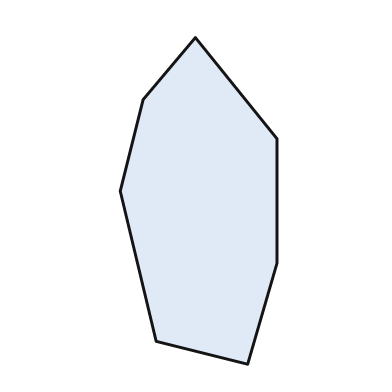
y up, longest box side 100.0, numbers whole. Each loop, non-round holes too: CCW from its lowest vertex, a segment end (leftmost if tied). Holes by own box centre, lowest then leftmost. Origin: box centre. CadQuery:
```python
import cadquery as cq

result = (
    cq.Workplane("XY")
    .moveTo(15.0, -50.0)
    .lineTo(24.0, -19.0)
    .lineTo(24.0, 19.0)
    .lineTo(-1.0, 50.0)
    .lineTo(-17.0, 31.0)
    .lineTo(-24.0, 3.0)
    .lineTo(-13.0, -43.0)
    .close()
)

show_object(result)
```